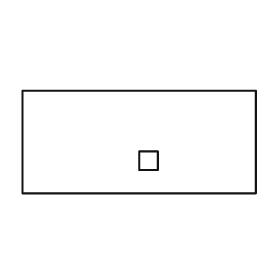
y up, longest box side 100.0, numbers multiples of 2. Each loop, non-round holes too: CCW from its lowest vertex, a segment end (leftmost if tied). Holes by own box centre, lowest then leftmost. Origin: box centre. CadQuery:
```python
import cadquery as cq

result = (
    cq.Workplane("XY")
    .moveTo(-50.0, -22.0)
    .lineTo(50.0, -22.0)
    .lineTo(50.0, 22.0)
    .lineTo(-50.0, 22.0)
    .close()
    .moveTo(0.0, -12.0)
    .lineTo(8.0, -12.0)
    .lineTo(8.0, -4.0)
    .lineTo(0.0, -4.0)
    .close()
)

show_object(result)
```